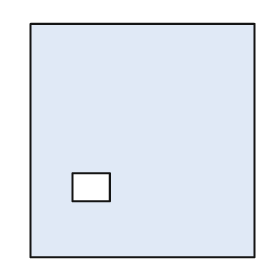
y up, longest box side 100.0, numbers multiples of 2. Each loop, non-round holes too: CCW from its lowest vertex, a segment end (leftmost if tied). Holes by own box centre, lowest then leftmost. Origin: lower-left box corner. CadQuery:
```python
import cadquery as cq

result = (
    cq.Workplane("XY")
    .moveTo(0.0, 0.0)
    .lineTo(96.0, 0.0)
    .lineTo(96.0, 100.0)
    .lineTo(0.0, 100.0)
    .close()
    .moveTo(18.0, 24.0)
    .lineTo(34.0, 24.0)
    .lineTo(34.0, 36.0)
    .lineTo(18.0, 36.0)
    .close()
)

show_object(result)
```